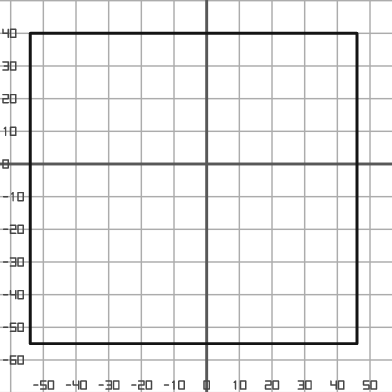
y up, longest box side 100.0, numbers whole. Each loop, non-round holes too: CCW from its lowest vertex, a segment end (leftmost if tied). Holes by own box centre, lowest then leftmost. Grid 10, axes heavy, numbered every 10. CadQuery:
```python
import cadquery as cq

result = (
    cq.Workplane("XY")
    .moveTo(-54.0, -55.0)
    .lineTo(46.0, -55.0)
    .lineTo(46.0, 40.0)
    .lineTo(-54.0, 40.0)
    .close()
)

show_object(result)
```